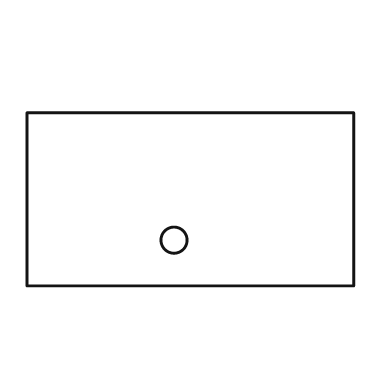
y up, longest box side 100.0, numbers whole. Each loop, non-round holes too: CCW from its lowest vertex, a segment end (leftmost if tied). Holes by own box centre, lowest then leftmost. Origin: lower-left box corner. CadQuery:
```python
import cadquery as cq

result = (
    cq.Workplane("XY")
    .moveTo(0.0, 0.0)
    .lineTo(100.0, 0.0)
    .lineTo(100.0, 53.0)
    .lineTo(0.0, 53.0)
    .close()
    .moveTo(45.0, 14.0)
    .circle(4.0)
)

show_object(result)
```